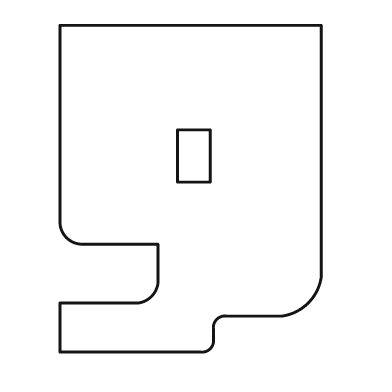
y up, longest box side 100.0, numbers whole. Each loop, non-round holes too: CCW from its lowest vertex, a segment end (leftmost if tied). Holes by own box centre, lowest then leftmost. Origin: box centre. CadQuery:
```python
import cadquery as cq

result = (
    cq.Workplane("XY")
    .moveTo(-40.0, -50.0)
    .lineTo(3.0, -50.0)
    .threePointArc((6.0, -49.0), (7.0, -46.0))
    .lineTo(7.0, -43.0)
    .threePointArc((8.0, -40.0), (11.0, -39.0))
    .lineTo(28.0, -39.0)
    .threePointArc((36.0, -35.0), (40.0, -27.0))
    .lineTo(40.0, 50.0)
    .lineTo(-40.0, 50.0)
    .lineTo(-40.0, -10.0)
    .threePointArc((-38.0, -15.0), (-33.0, -17.0))
    .lineTo(-10.0, -17.0)
    .lineTo(-10.0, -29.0)
    .threePointArc((-12.0, -33.0), (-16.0, -35.0))
    .lineTo(-40.0, -35.0)
    .close()
    .moveTo(-4.0, 2.0)
    .lineTo(6.0, 2.0)
    .lineTo(6.0, 18.0)
    .lineTo(-4.0, 18.0)
    .close()
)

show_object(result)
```